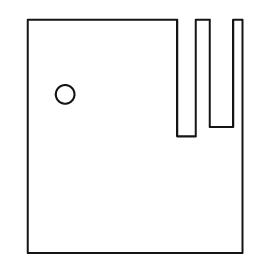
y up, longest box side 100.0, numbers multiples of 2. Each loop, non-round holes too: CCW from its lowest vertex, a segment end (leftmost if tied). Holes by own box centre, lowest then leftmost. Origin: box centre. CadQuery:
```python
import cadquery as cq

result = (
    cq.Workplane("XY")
    .moveTo(-46.0, -50.0)
    .lineTo(46.0, -50.0)
    .lineTo(46.0, 50.0)
    .lineTo(42.0, 50.0)
    .lineTo(42.0, 4.0)
    .lineTo(32.0, 4.0)
    .lineTo(32.0, 50.0)
    .lineTo(26.0, 50.0)
    .lineTo(26.0, 0.0)
    .lineTo(18.0, 0.0)
    .lineTo(18.0, 50.0)
    .lineTo(-46.0, 50.0)
    .close()
    .moveTo(-30.0, 18.0)
    .circle(4.0)
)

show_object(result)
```